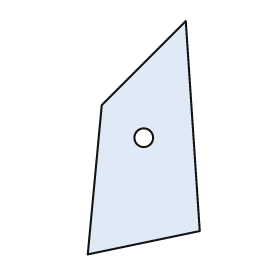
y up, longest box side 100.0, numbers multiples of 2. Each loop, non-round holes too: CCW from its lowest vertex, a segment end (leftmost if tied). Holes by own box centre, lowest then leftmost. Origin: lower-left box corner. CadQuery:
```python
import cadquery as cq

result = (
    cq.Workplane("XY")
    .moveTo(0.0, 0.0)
    .lineTo(48.0, 10.0)
    .lineTo(42.0, 100.0)
    .lineTo(6.0, 64.0)
    .close()
    .moveTo(24.0, 50.0)
    .circle(4.0)
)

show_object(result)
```